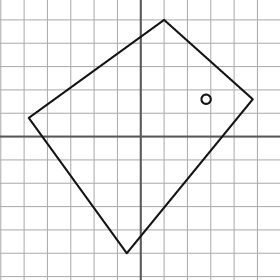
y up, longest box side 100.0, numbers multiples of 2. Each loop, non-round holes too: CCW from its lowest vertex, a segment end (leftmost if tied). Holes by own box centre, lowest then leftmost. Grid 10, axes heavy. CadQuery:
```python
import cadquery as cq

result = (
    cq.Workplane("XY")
    .moveTo(-6.0, -50.0)
    .lineTo(48.0, 16.0)
    .lineTo(10.0, 50.0)
    .lineTo(-48.0, 8.0)
    .close()
    .moveTo(28.0, 16.0)
    .circle(2.0)
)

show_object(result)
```